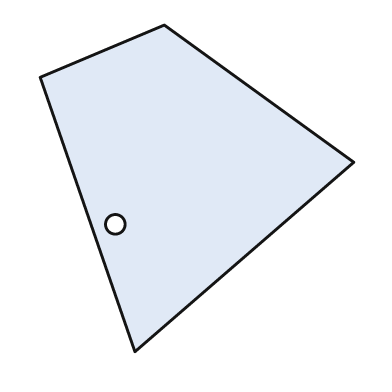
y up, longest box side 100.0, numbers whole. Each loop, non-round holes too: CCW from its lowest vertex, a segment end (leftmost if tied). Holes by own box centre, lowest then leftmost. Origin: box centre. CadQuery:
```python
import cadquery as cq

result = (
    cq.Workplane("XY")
    .moveTo(-19.0, -50.0)
    .lineTo(48.0, 8.0)
    .lineTo(-10.0, 50.0)
    .lineTo(-48.0, 34.0)
    .close()
    .moveTo(-25.0, -11.0)
    .circle(3.0)
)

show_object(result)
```